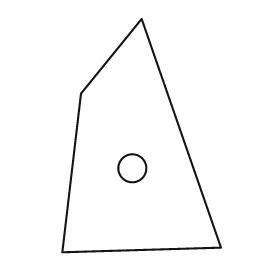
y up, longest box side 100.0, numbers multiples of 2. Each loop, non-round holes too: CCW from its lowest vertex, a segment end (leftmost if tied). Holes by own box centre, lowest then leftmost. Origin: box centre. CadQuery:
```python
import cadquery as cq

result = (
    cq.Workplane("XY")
    .moveTo(-34.0, -50.0)
    .lineTo(34.0, -48.0)
    .lineTo(0.0, 50.0)
    .lineTo(-26.0, 18.0)
    .close()
    .moveTo(-4.0, -14.0)
    .circle(6.0)
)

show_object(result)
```